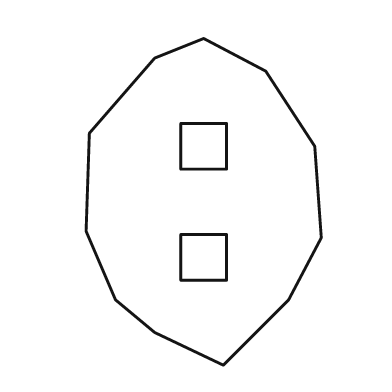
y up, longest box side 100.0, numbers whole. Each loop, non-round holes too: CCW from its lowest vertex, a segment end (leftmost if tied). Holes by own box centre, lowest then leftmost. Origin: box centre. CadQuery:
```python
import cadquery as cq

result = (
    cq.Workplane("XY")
    .moveTo(6.0, -50.0)
    .lineTo(26.0, -30.0)
    .lineTo(36.0, -11.0)
    .lineTo(34.0, 17.0)
    .lineTo(19.0, 40.0)
    .lineTo(0.0, 50.0)
    .lineTo(-15.0, 44.0)
    .lineTo(-35.0, 21.0)
    .lineTo(-36.0, -9.0)
    .lineTo(-27.0, -30.0)
    .lineTo(-15.0, -40.0)
    .close()
    .moveTo(-7.0, -24.0)
    .lineTo(7.0, -24.0)
    .lineTo(7.0, -10.0)
    .lineTo(-7.0, -10.0)
    .close()
    .moveTo(-7.0, 10.0)
    .lineTo(7.0, 10.0)
    .lineTo(7.0, 24.0)
    .lineTo(-7.0, 24.0)
    .close()
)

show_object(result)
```